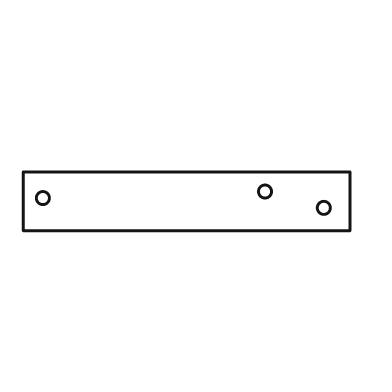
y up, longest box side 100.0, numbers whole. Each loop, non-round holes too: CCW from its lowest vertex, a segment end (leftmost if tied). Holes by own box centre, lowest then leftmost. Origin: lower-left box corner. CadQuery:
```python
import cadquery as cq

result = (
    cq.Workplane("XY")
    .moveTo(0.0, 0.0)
    .lineTo(100.0, 0.0)
    .lineTo(100.0, 18.0)
    .lineTo(0.0, 18.0)
    .close()
    .moveTo(92.0, 7.0)
    .circle(2.0)
    .moveTo(6.0, 10.0)
    .circle(2.0)
    .moveTo(74.0, 12.0)
    .circle(2.0)
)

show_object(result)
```